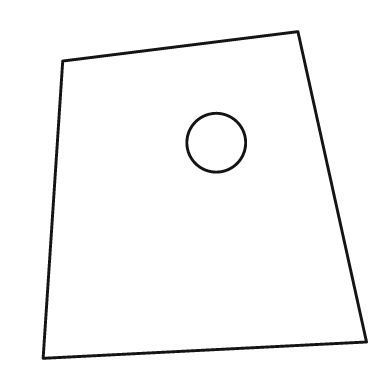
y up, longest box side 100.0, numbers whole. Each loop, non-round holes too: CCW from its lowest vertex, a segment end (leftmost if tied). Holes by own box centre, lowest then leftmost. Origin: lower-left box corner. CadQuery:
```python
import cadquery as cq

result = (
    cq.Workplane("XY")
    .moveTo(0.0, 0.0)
    .lineTo(99.0, 5.0)
    .lineTo(78.0, 100.0)
    .lineTo(6.0, 91.0)
    .close()
    .moveTo(53.0, 66.0)
    .circle(9.0)
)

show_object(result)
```